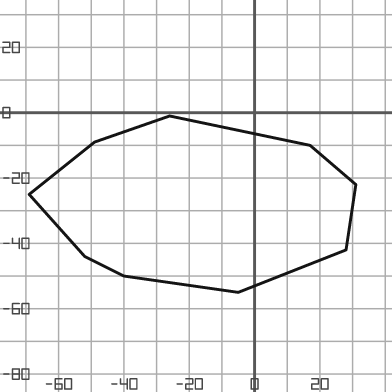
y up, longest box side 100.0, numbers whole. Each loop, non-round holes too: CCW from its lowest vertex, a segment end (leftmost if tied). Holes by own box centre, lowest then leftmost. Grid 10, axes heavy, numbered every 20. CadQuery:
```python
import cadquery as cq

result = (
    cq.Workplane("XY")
    .moveTo(-5.0, -55.0)
    .lineTo(28.0, -42.0)
    .lineTo(31.0, -22.0)
    .lineTo(17.0, -10.0)
    .lineTo(-26.0, -1.0)
    .lineTo(-49.0, -9.0)
    .lineTo(-69.0, -25.0)
    .lineTo(-52.0, -44.0)
    .lineTo(-40.0, -50.0)
    .close()
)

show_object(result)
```